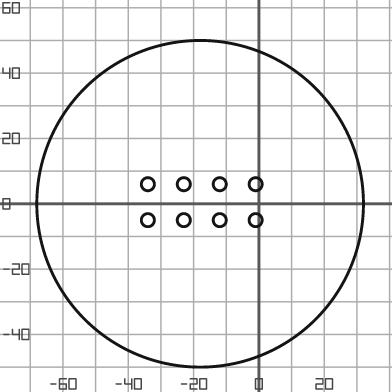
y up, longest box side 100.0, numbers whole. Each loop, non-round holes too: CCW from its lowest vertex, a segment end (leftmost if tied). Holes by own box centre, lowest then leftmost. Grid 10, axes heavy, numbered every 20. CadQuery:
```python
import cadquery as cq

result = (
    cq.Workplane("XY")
    .moveTo(-18.0, 0.0)
    .circle(50.0)
    .moveTo(-34.0, -5.0)
    .circle(2.0)
    .moveTo(-23.0, -5.0)
    .circle(2.0)
    .moveTo(-12.0, -5.0)
    .circle(2.0)
    .moveTo(-1.0, -5.0)
    .circle(2.0)
    .moveTo(-34.0, 6.0)
    .circle(2.0)
    .moveTo(-23.0, 6.0)
    .circle(2.0)
    .moveTo(-12.0, 6.0)
    .circle(2.0)
    .moveTo(-1.0, 6.0)
    .circle(2.0)
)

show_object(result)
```